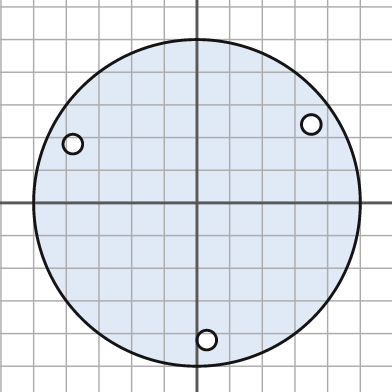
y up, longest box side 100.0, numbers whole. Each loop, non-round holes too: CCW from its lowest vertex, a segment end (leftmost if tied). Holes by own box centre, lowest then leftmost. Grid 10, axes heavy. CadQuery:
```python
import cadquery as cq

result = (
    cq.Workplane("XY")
    .moveTo(0.0, 0.0)
    .circle(50.0)
    .moveTo(3.0, -42.0)
    .circle(3.0)
    .moveTo(-38.0, 18.0)
    .circle(3.0)
    .moveTo(35.0, 24.0)
    .circle(3.0)
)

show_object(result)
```